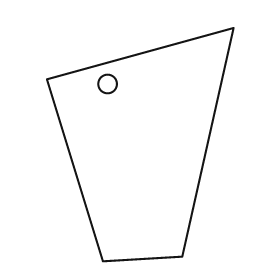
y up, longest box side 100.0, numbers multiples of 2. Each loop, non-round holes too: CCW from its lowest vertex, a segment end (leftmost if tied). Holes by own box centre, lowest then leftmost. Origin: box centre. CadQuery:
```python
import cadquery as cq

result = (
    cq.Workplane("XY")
    .moveTo(-16.0, -50.0)
    .lineTo(18.0, -48.0)
    .lineTo(40.0, 50.0)
    .lineTo(-40.0, 28.0)
    .close()
    .moveTo(-14.0, 26.0)
    .circle(4.0)
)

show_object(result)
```